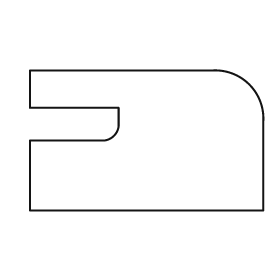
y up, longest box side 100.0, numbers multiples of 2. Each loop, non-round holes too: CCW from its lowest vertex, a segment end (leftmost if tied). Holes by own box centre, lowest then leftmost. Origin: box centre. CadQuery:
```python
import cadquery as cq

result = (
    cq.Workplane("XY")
    .moveTo(-50.0, -30.0)
    .lineTo(50.0, -30.0)
    .lineTo(50.0, 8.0)
    .threePointArc((44.0, 24.0), (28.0, 30.0))
    .lineTo(-50.0, 30.0)
    .lineTo(-50.0, 14.0)
    .lineTo(-12.0, 14.0)
    .lineTo(-12.0, 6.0)
    .threePointArc((-14.0, 2.0), (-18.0, 0.0))
    .lineTo(-50.0, 0.0)
    .close()
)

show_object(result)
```